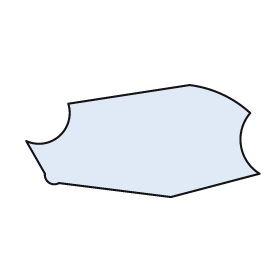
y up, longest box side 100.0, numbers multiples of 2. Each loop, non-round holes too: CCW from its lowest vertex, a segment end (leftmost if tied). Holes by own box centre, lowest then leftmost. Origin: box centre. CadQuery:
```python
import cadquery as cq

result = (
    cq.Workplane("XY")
    .moveTo(12.0, -24.0)
    .lineTo(50.0, -14.0)
    .threePointArc((42.0, -2.0), (46.0, 12.0))
    .threePointArc((34.0, 20.0), (20.0, 24.0))
    .lineTo(-32.0, 16.0)
    .threePointArc((-36.0, 2.0), (-50.0, 0.0))
    .lineTo(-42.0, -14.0)
    .threePointArc((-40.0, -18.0), (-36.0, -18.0))
    .close()
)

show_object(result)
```